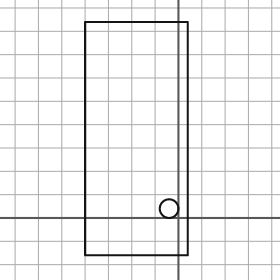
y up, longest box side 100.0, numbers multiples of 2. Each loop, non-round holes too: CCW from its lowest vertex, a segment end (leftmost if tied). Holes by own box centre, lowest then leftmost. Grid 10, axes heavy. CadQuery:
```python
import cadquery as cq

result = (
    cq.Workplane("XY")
    .moveTo(-40.0, -16.0)
    .lineTo(4.0, -16.0)
    .lineTo(4.0, 84.0)
    .lineTo(-40.0, 84.0)
    .close()
    .moveTo(-4.0, 4.0)
    .circle(4.0)
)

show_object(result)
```